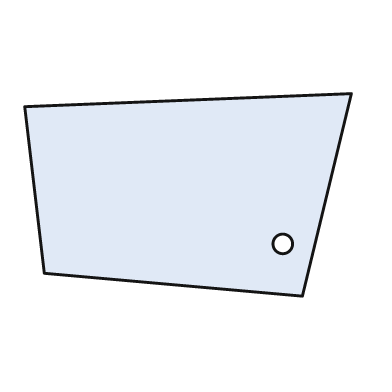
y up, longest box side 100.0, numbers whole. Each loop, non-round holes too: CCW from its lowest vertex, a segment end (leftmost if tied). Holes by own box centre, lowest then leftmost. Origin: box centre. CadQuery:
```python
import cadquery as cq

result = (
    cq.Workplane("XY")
    .moveTo(35.0, -31.0)
    .lineTo(50.0, 31.0)
    .lineTo(-50.0, 27.0)
    .lineTo(-44.0, -24.0)
    .close()
    .moveTo(29.0, -15.0)
    .circle(3.0)
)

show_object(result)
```